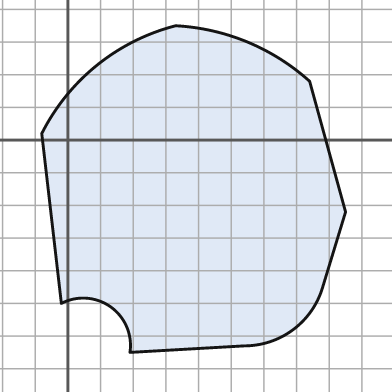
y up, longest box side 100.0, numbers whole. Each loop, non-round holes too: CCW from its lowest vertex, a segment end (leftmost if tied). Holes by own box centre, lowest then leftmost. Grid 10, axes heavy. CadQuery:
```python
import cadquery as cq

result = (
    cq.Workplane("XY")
    .moveTo(19.0, -65.0)
    .lineTo(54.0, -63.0)
    .threePointArc((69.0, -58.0), (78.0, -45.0))
    .lineTo(85.0, -22.0)
    .lineTo(74.0, 18.0)
    .threePointArc((55.0, 30.0), (33.0, 35.0))
    .threePointArc((9.0, 23.0), (-8.0, 2.0))
    .lineTo(-2.0, -50.0)
    .threePointArc((13.0, -51.0), (19.0, -65.0))
    .close()
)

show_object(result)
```